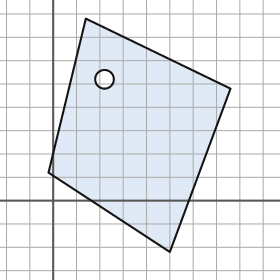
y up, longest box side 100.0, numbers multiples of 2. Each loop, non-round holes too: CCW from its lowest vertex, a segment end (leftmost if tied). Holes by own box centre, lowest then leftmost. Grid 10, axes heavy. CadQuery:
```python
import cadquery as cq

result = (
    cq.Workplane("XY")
    .moveTo(50.0, -22.0)
    .lineTo(76.0, 48.0)
    .lineTo(14.0, 78.0)
    .lineTo(-2.0, 12.0)
    .close()
    .moveTo(22.0, 52.0)
    .circle(4.0)
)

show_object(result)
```